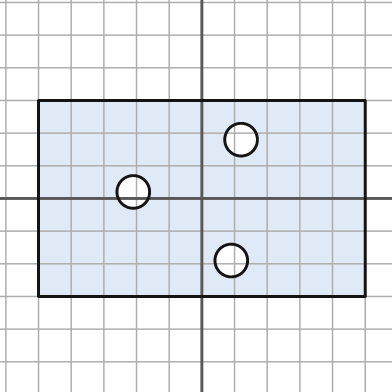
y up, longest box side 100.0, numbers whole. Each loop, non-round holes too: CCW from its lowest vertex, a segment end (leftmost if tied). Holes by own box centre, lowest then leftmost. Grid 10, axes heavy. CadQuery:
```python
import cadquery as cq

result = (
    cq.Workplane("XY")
    .moveTo(-50.0, -30.0)
    .lineTo(50.0, -30.0)
    .lineTo(50.0, 30.0)
    .lineTo(-50.0, 30.0)
    .close()
    .moveTo(9.0, -19.0)
    .circle(5.0)
    .moveTo(-21.0, 2.0)
    .circle(5.0)
    .moveTo(12.0, 18.0)
    .circle(5.0)
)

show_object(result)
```